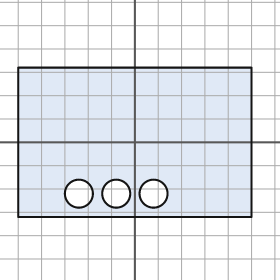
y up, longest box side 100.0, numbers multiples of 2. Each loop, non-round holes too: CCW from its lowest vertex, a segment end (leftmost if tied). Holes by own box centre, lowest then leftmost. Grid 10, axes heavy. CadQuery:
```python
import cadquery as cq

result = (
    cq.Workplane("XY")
    .moveTo(-50.0, -32.0)
    .lineTo(50.0, -32.0)
    .lineTo(50.0, 32.0)
    .lineTo(-50.0, 32.0)
    .close()
    .moveTo(-24.0, -22.0)
    .circle(6.0)
    .moveTo(-8.0, -22.0)
    .circle(6.0)
    .moveTo(8.0, -22.0)
    .circle(6.0)
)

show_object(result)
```